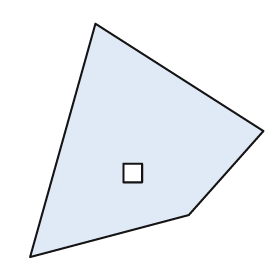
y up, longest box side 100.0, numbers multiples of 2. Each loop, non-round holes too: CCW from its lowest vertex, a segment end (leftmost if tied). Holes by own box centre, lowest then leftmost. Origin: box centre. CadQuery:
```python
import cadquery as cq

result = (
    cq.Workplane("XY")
    .moveTo(-50.0, -50.0)
    .lineTo(18.0, -32.0)
    .lineTo(50.0, 4.0)
    .lineTo(-22.0, 50.0)
    .close()
    .moveTo(-10.0, -18.0)
    .lineTo(-2.0, -18.0)
    .lineTo(-2.0, -10.0)
    .lineTo(-10.0, -10.0)
    .close()
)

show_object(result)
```